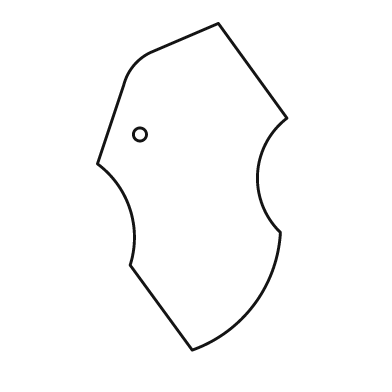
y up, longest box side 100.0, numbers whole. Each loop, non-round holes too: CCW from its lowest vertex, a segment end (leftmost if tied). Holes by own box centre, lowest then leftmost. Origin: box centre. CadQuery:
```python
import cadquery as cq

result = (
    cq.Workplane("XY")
    .moveTo(0.0, -50.0)
    .threePointArc((19.0, -36.0), (27.0, -14.0))
    .threePointArc((20.0, 4.0), (29.0, 21.0))
    .lineTo(8.0, 50.0)
    .lineTo(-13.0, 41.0)
    .threePointArc((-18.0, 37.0), (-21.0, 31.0))
    .lineTo(-29.0, 7.0)
    .threePointArc((-19.0, -7.0), (-19.0, -24.0))
    .close()
    .moveTo(-16.0, 16.0)
    .circle(2.0)
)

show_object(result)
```